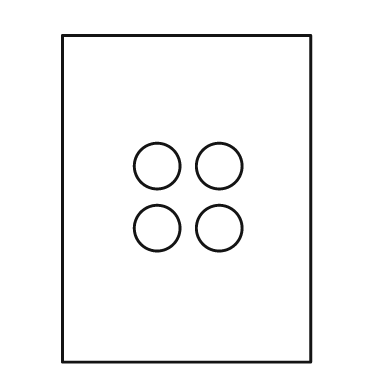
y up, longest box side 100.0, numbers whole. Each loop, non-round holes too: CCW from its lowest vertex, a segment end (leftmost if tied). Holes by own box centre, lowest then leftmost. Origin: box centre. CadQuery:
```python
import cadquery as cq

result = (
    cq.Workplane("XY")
    .moveTo(-38.0, -50.0)
    .lineTo(38.0, -50.0)
    .lineTo(38.0, 50.0)
    .lineTo(-38.0, 50.0)
    .close()
    .moveTo(-9.0, -9.0)
    .circle(7.0)
    .moveTo(10.0, -9.0)
    .circle(7.0)
    .moveTo(-9.0, 10.0)
    .circle(7.0)
    .moveTo(10.0, 10.0)
    .circle(7.0)
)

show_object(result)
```